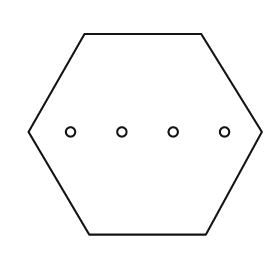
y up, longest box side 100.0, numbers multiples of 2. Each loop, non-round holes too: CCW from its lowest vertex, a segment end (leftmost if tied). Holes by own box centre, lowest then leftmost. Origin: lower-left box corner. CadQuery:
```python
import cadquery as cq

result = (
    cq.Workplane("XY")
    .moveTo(26.0, 0.0)
    .lineTo(76.0, 0.0)
    .lineTo(100.0, 44.0)
    .lineTo(74.0, 86.0)
    .lineTo(24.0, 86.0)
    .lineTo(0.0, 44.0)
    .close()
    .moveTo(18.0, 44.0)
    .circle(2.0)
    .moveTo(40.0, 44.0)
    .circle(2.0)
    .moveTo(62.0, 44.0)
    .circle(2.0)
    .moveTo(84.0, 44.0)
    .circle(2.0)
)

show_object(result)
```